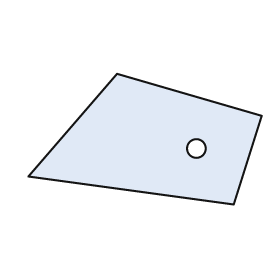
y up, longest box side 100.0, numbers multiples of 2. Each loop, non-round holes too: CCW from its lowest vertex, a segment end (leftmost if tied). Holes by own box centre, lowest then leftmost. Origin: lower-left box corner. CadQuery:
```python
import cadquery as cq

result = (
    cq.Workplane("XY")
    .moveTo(88.0, 0.0)
    .lineTo(100.0, 38.0)
    .lineTo(38.0, 56.0)
    .lineTo(0.0, 12.0)
    .close()
    .moveTo(72.0, 24.0)
    .circle(4.0)
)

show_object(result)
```